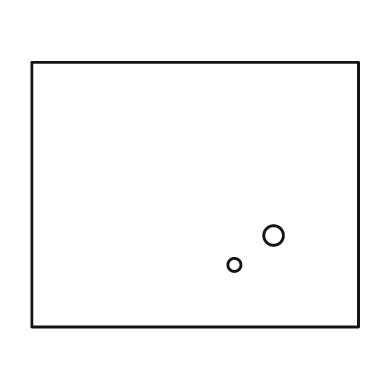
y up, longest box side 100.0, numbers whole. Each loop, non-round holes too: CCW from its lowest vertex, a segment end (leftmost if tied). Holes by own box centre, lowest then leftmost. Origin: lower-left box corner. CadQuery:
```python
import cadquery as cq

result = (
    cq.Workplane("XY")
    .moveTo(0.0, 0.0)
    .lineTo(100.0, 0.0)
    .lineTo(100.0, 81.0)
    .lineTo(0.0, 81.0)
    .close()
    .moveTo(62.0, 19.0)
    .circle(2.0)
    .moveTo(74.0, 28.0)
    .circle(3.0)
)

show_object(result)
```